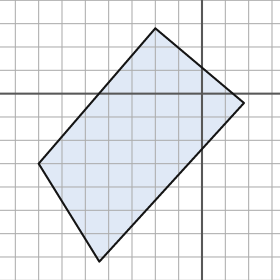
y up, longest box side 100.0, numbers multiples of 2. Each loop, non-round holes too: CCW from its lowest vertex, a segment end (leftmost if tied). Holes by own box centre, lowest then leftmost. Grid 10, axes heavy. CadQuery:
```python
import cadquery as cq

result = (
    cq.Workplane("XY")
    .moveTo(-44.0, -72.0)
    .lineTo(18.0, -4.0)
    .lineTo(-20.0, 28.0)
    .lineTo(-70.0, -30.0)
    .close()
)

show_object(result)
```